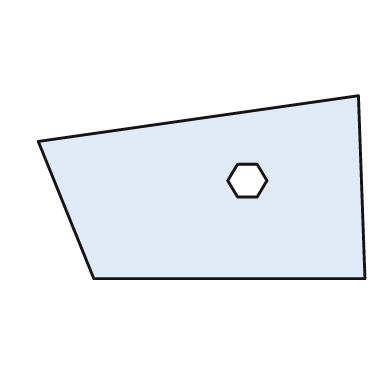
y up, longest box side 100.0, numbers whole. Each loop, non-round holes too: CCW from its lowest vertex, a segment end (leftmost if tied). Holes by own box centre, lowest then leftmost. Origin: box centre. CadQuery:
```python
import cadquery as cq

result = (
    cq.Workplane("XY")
    .moveTo(-33.0, -28.0)
    .lineTo(50.0, -28.0)
    .lineTo(48.0, 28.0)
    .lineTo(-50.0, 14.0)
    .close()
    .moveTo(11.0, -3.0)
    .lineTo(17.0, -3.0)
    .lineTo(20.0, 2.0)
    .lineTo(17.0, 7.0)
    .lineTo(11.0, 7.0)
    .lineTo(8.0, 2.0)
    .close()
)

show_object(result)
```